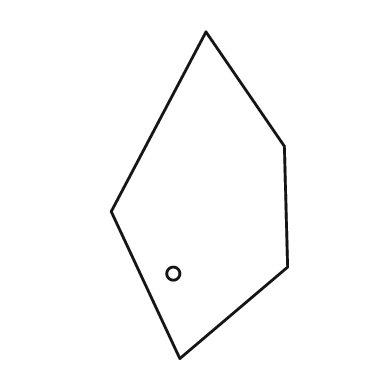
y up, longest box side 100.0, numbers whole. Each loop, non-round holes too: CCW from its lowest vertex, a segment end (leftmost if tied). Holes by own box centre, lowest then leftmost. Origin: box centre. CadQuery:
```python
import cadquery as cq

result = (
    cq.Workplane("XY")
    .moveTo(-6.0, -50.0)
    .lineTo(27.0, -22.0)
    .lineTo(26.0, 15.0)
    .lineTo(2.0, 50.0)
    .lineTo(-27.0, -5.0)
    .close()
    .moveTo(-8.0, -24.0)
    .circle(2.0)
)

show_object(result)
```